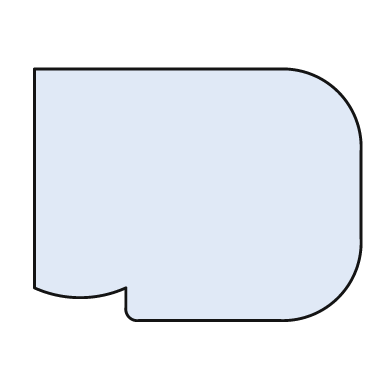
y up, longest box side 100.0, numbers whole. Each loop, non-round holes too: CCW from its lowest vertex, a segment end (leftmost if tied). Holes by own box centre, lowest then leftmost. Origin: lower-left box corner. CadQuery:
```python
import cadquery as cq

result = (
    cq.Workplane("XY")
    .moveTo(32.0, 0.0)
    .lineTo(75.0, 0.0)
    .threePointArc((93.0, 7.0), (100.0, 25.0))
    .lineTo(100.0, 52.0)
    .threePointArc((93.0, 70.0), (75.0, 77.0))
    .lineTo(0.0, 77.0)
    .lineTo(0.0, 10.0)
    .threePointArc((14.0, 7.0), (28.0, 10.0))
    .lineTo(28.0, 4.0)
    .threePointArc((29.0, 1.0), (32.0, 0.0))
    .close()
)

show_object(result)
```